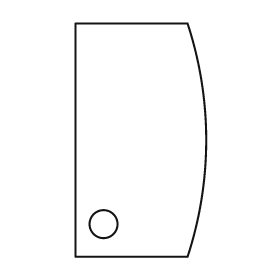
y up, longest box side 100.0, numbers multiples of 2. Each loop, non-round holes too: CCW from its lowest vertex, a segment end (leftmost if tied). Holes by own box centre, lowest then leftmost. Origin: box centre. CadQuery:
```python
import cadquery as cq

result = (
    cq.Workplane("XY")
    .moveTo(-28.0, -50.0)
    .lineTo(20.0, -50.0)
    .threePointArc((28.0, 0.0), (20.0, 50.0))
    .lineTo(-28.0, 50.0)
    .close()
    .moveTo(-16.0, -36.0)
    .circle(6.0)
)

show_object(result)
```